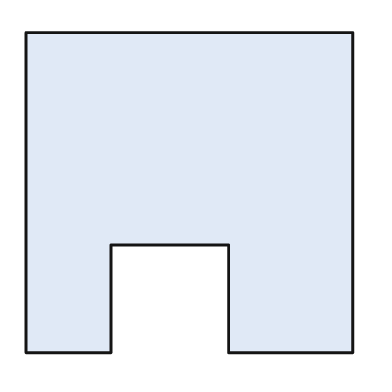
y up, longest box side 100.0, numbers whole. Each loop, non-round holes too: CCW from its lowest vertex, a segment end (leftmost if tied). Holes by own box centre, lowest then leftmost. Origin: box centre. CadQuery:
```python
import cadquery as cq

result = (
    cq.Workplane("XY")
    .moveTo(-50.0, -49.0)
    .lineTo(-24.0, -49.0)
    .lineTo(-24.0, -16.0)
    .lineTo(12.0, -16.0)
    .lineTo(12.0, -49.0)
    .lineTo(50.0, -49.0)
    .lineTo(50.0, 49.0)
    .lineTo(-50.0, 49.0)
    .close()
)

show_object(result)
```